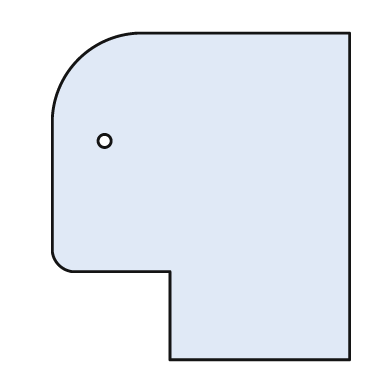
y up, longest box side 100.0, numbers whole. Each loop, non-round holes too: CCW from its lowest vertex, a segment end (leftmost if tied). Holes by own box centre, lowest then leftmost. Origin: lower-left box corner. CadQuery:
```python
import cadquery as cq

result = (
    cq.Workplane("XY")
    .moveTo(36.0, 0.0)
    .lineTo(91.0, 0.0)
    .lineTo(91.0, 100.0)
    .lineTo(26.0, 100.0)
    .threePointArc((8.0, 92.0), (0.0, 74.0))
    .lineTo(0.0, 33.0)
    .threePointArc((2.0, 29.0), (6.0, 27.0))
    .lineTo(36.0, 27.0)
    .close()
    .moveTo(16.0, 67.0)
    .circle(2.0)
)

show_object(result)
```